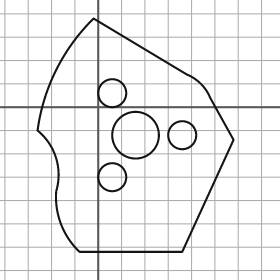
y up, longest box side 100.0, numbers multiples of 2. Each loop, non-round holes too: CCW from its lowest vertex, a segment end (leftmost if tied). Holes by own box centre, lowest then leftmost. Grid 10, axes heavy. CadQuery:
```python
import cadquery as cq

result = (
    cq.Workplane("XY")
    .moveTo(-8.0, -62.0)
    .lineTo(36.0, -62.0)
    .lineTo(58.0, -14.0)
    .lineTo(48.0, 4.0)
    .threePointArc((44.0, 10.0), (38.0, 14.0))
    .lineTo(-2.0, 38.0)
    .threePointArc((-18.0, 16.0), (-26.0, -10.0))
    .threePointArc((-18.0, -22.0), (-18.0, -36.0))
    .threePointArc((-16.0, -50.0), (-8.0, -62.0))
    .close()
    .moveTo(6.0, -30.0)
    .circle(6.0)
    .moveTo(16.0, -12.0)
    .circle(10.0)
    .moveTo(36.0, -12.0)
    .circle(6.0)
    .moveTo(6.0, 6.0)
    .circle(6.0)
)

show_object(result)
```